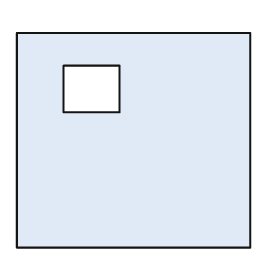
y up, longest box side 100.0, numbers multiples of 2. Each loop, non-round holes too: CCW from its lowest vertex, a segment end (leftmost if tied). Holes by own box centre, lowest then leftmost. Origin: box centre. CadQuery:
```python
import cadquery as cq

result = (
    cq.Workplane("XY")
    .moveTo(-50.0, -46.0)
    .lineTo(50.0, -46.0)
    .lineTo(50.0, 46.0)
    .lineTo(-50.0, 46.0)
    .close()
    .moveTo(-30.0, 12.0)
    .lineTo(-6.0, 12.0)
    .lineTo(-6.0, 32.0)
    .lineTo(-30.0, 32.0)
    .close()
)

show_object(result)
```